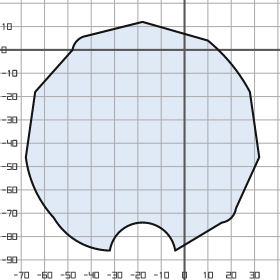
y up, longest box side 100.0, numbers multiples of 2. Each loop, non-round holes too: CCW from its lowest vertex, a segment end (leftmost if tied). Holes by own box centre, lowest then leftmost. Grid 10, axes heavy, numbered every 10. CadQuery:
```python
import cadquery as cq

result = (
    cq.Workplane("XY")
    .moveTo(-32.0, -86.0)
    .threePointArc((-18.0, -74.0), (-4.0, -86.0))
    .lineTo(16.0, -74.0)
    .threePointArc((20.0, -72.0), (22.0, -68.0))
    .lineTo(32.0, -46.0)
    .lineTo(28.0, -18.0)
    .threePointArc((20.0, -6.0), (10.0, 4.0))
    .lineTo(-18.0, 12.0)
    .lineTo(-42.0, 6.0)
    .threePointArc((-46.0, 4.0), (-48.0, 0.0))
    .lineTo(-64.0, -18.0)
    .lineTo(-68.0, -46.0)
    .threePointArc((-64.0, -60.0), (-56.0, -72.0))
    .threePointArc((-46.0, -82.0), (-32.0, -86.0))
    .close()
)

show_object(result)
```